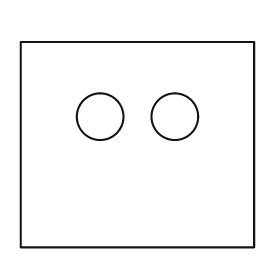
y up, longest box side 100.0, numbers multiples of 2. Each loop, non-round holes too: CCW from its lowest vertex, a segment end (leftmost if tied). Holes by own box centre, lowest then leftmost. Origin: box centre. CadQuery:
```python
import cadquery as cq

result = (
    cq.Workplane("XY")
    .moveTo(-50.0, -44.0)
    .lineTo(50.0, -44.0)
    .lineTo(50.0, 44.0)
    .lineTo(-50.0, 44.0)
    .close()
    .moveTo(-16.0, 12.0)
    .circle(10.0)
    .moveTo(16.0, 12.0)
    .circle(10.0)
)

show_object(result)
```